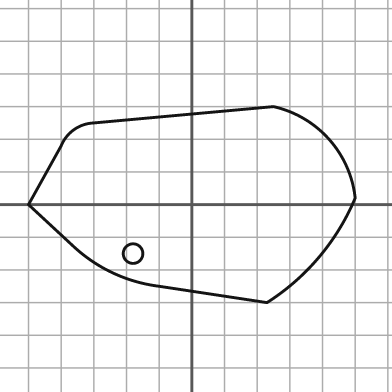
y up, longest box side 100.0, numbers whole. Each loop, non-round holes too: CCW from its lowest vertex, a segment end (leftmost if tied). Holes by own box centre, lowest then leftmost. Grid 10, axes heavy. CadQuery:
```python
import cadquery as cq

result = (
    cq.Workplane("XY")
    .moveTo(23.0, -30.0)
    .threePointArc((39.0, -16.0), (50.0, 2.0))
    .threePointArc((42.0, 20.0), (25.0, 30.0))
    .lineTo(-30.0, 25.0)
    .threePointArc((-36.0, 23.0), (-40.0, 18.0))
    .lineTo(-50.0, 0.0)
    .lineTo(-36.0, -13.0)
    .threePointArc((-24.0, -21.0), (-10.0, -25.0))
    .close()
    .moveTo(-18.0, -15.0)
    .circle(3.0)
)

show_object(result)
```